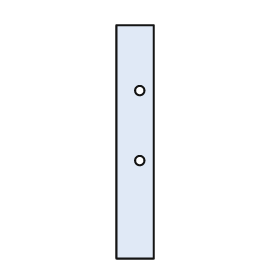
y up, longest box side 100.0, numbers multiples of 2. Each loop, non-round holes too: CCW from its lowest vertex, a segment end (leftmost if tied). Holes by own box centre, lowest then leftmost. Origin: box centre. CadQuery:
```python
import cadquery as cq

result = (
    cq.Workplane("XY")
    .moveTo(-8.0, -50.0)
    .lineTo(8.0, -50.0)
    .lineTo(8.0, 50.0)
    .lineTo(-8.0, 50.0)
    .close()
    .moveTo(2.0, -8.0)
    .circle(2.0)
    .moveTo(2.0, 22.0)
    .circle(2.0)
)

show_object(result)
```